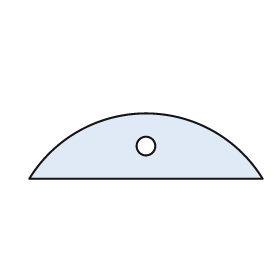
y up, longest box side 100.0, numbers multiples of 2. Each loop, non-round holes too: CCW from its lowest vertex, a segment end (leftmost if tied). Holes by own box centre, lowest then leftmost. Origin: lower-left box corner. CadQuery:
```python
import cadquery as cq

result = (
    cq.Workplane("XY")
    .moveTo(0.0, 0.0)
    .lineTo(100.0, 0.0)
    .threePointArc((50.0, 28.0), (0.0, 0.0))
    .close()
    .moveTo(50.0, 14.0)
    .circle(4.0)
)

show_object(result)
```